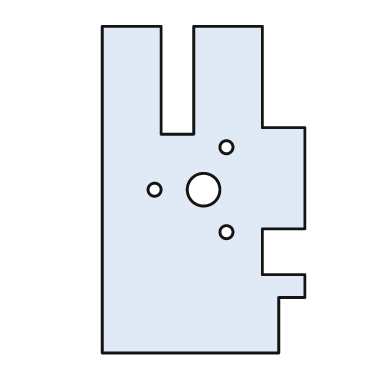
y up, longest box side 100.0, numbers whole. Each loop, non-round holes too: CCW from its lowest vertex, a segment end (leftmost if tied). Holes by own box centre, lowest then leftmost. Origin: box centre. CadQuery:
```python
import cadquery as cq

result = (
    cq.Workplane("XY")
    .moveTo(-31.0, -50.0)
    .lineTo(23.0, -50.0)
    .lineTo(23.0, -33.0)
    .lineTo(31.0, -33.0)
    .lineTo(31.0, -26.0)
    .lineTo(18.0, -26.0)
    .lineTo(18.0, -12.0)
    .lineTo(31.0, -12.0)
    .lineTo(31.0, 19.0)
    .lineTo(18.0, 19.0)
    .lineTo(18.0, 50.0)
    .lineTo(-3.0, 50.0)
    .lineTo(-3.0, 17.0)
    .lineTo(-13.0, 17.0)
    .lineTo(-13.0, 50.0)
    .lineTo(-31.0, 50.0)
    .close()
    .moveTo(7.0, -13.0)
    .circle(2.0)
    .moveTo(-15.0, 0.0)
    .circle(2.0)
    .moveTo(0.0, 0.0)
    .circle(5.0)
    .moveTo(7.0, 13.0)
    .circle(2.0)
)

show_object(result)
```